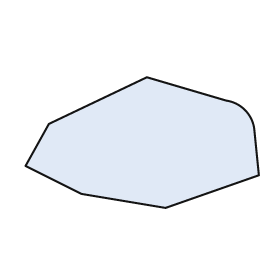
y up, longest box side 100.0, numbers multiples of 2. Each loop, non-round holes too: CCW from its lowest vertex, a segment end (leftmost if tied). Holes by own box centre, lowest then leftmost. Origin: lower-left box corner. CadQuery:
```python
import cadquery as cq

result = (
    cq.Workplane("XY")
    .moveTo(60.0, 0.0)
    .lineTo(100.0, 14.0)
    .lineTo(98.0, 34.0)
    .threePointArc((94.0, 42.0), (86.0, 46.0))
    .lineTo(52.0, 56.0)
    .lineTo(10.0, 36.0)
    .lineTo(0.0, 18.0)
    .lineTo(24.0, 6.0)
    .close()
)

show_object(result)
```